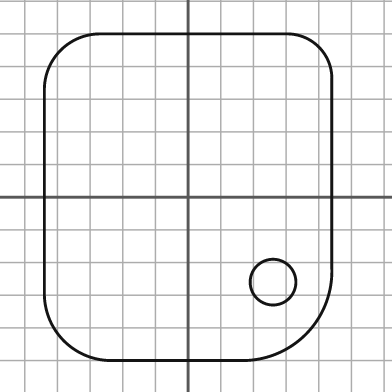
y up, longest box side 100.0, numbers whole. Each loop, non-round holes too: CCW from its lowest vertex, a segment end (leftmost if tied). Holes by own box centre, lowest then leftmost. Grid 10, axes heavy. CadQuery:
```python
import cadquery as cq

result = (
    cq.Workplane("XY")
    .moveTo(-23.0, -50.0)
    .lineTo(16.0, -50.0)
    .threePointArc((36.0, -42.0), (44.0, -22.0))
    .lineTo(44.0, 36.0)
    .threePointArc((40.0, 46.0), (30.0, 50.0))
    .lineTo(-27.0, 50.0)
    .threePointArc((-39.0, 45.0), (-44.0, 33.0))
    .lineTo(-44.0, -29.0)
    .threePointArc((-38.0, -44.0), (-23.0, -50.0))
    .close()
    .moveTo(26.0, -26.0)
    .circle(7.0)
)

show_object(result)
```